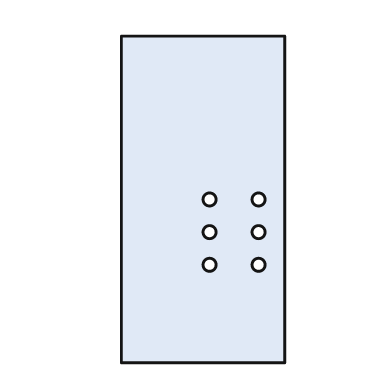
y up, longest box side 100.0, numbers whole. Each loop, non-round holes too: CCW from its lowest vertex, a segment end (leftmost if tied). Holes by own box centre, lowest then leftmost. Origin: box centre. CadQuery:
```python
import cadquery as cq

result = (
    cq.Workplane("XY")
    .moveTo(-25.0, -50.0)
    .lineTo(25.0, -50.0)
    .lineTo(25.0, 50.0)
    .lineTo(-25.0, 50.0)
    .close()
    .moveTo(2.0, -20.0)
    .circle(2.0)
    .moveTo(17.0, -20.0)
    .circle(2.0)
    .moveTo(2.0, -10.0)
    .circle(2.0)
    .moveTo(17.0, -10.0)
    .circle(2.0)
    .moveTo(2.0, 0.0)
    .circle(2.0)
    .moveTo(17.0, 0.0)
    .circle(2.0)
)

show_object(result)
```